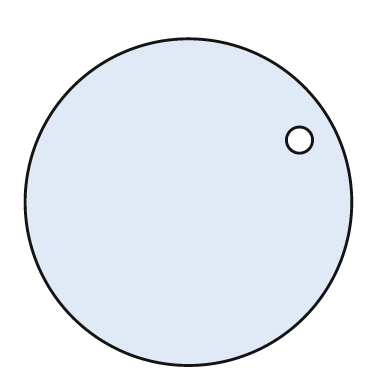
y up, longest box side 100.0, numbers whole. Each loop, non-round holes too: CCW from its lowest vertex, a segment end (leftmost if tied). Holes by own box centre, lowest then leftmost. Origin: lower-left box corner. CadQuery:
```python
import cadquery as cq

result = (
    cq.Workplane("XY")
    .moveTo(50.0, 50.0)
    .circle(50.0)
    .moveTo(84.0, 69.0)
    .circle(4.0)
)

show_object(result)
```